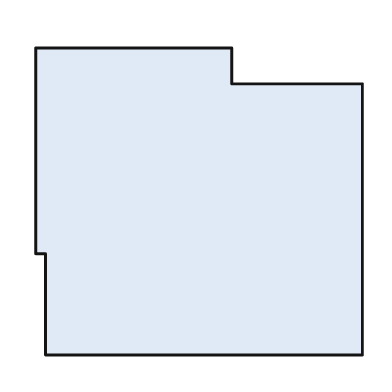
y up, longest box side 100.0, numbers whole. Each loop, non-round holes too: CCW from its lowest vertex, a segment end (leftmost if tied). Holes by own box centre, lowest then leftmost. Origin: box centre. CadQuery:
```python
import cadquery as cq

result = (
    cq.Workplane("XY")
    .moveTo(-47.0, -47.0)
    .lineTo(50.0, -47.0)
    .lineTo(50.0, 36.0)
    .lineTo(10.0, 36.0)
    .lineTo(10.0, 47.0)
    .lineTo(-50.0, 47.0)
    .lineTo(-50.0, -16.0)
    .lineTo(-47.0, -16.0)
    .close()
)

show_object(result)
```